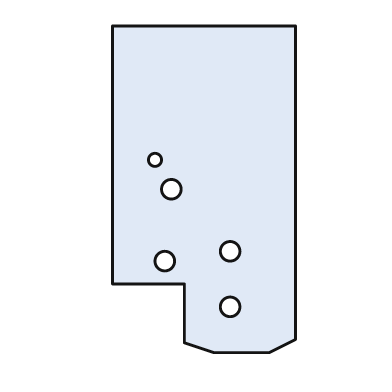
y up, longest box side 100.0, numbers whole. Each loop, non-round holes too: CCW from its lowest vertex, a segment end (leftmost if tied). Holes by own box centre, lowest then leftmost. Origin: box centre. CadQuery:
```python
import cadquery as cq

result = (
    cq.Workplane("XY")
    .moveTo(3.0, -50.0)
    .lineTo(20.0, -50.0)
    .lineTo(28.0, -46.0)
    .lineTo(28.0, 50.0)
    .lineTo(-28.0, 50.0)
    .lineTo(-28.0, -29.0)
    .lineTo(-6.0, -29.0)
    .lineTo(-6.0, -47.0)
    .close()
    .moveTo(8.0, -36.0)
    .circle(3.0)
    .moveTo(-12.0, -22.0)
    .circle(3.0)
    .moveTo(8.0, -19.0)
    .circle(3.0)
    .moveTo(-10.0, 0.0)
    .circle(3.0)
    .moveTo(-15.0, 9.0)
    .circle(2.0)
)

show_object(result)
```